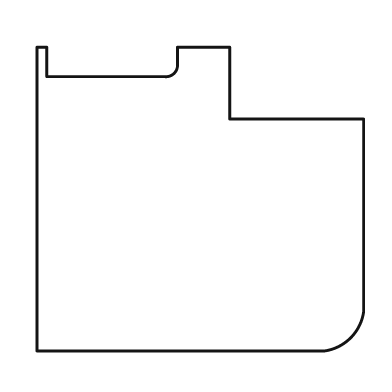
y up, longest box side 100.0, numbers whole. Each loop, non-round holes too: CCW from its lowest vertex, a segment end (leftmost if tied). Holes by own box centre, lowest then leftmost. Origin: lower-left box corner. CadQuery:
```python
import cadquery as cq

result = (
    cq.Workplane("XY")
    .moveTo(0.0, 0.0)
    .lineTo(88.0, 0.0)
    .threePointArc((96.0, 4.0), (100.0, 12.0))
    .lineTo(100.0, 71.0)
    .lineTo(59.0, 71.0)
    .lineTo(59.0, 93.0)
    .lineTo(43.0, 93.0)
    .lineTo(43.0, 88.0)
    .threePointArc((42.0, 85.0), (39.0, 84.0))
    .lineTo(3.0, 84.0)
    .lineTo(3.0, 93.0)
    .lineTo(0.0, 93.0)
    .close()
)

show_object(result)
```